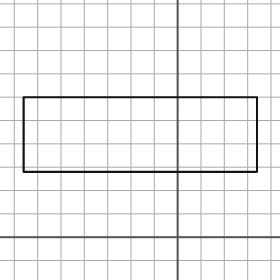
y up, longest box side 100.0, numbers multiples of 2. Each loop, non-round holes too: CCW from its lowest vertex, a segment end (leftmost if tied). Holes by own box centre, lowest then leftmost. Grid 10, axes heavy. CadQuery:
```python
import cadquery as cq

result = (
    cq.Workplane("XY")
    .moveTo(-66.0, 28.0)
    .lineTo(34.0, 28.0)
    .lineTo(34.0, 60.0)
    .lineTo(-66.0, 60.0)
    .close()
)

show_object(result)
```